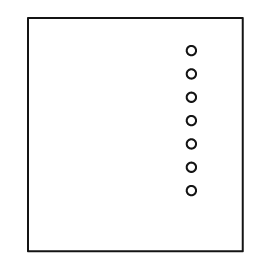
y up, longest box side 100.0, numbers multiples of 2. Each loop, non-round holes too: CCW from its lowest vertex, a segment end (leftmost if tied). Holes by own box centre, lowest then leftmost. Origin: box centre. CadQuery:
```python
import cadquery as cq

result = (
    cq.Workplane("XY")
    .moveTo(-46.0, -50.0)
    .lineTo(46.0, -50.0)
    .lineTo(46.0, 50.0)
    .lineTo(-46.0, 50.0)
    .close()
    .moveTo(24.0, -24.0)
    .circle(2.0)
    .moveTo(24.0, -14.0)
    .circle(2.0)
    .moveTo(24.0, -4.0)
    .circle(2.0)
    .moveTo(24.0, 6.0)
    .circle(2.0)
    .moveTo(24.0, 16.0)
    .circle(2.0)
    .moveTo(24.0, 26.0)
    .circle(2.0)
    .moveTo(24.0, 36.0)
    .circle(2.0)
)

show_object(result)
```